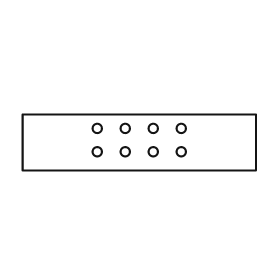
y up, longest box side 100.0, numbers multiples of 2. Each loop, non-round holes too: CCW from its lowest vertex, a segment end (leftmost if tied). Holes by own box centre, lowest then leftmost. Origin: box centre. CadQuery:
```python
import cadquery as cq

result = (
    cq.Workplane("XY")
    .moveTo(-50.0, -12.0)
    .lineTo(50.0, -12.0)
    .lineTo(50.0, 12.0)
    .lineTo(-50.0, 12.0)
    .close()
    .moveTo(-18.0, -4.0)
    .circle(2.0)
    .moveTo(-6.0, -4.0)
    .circle(2.0)
    .moveTo(6.0, -4.0)
    .circle(2.0)
    .moveTo(18.0, -4.0)
    .circle(2.0)
    .moveTo(-18.0, 6.0)
    .circle(2.0)
    .moveTo(-6.0, 6.0)
    .circle(2.0)
    .moveTo(6.0, 6.0)
    .circle(2.0)
    .moveTo(18.0, 6.0)
    .circle(2.0)
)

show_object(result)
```